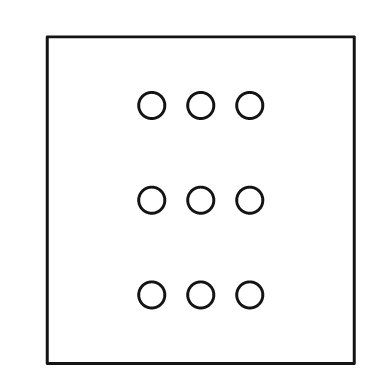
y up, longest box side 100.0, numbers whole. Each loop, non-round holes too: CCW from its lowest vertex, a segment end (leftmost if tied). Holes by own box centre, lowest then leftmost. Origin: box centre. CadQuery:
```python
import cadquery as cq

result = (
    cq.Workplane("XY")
    .moveTo(-47.0, -50.0)
    .lineTo(47.0, -50.0)
    .lineTo(47.0, 50.0)
    .lineTo(-47.0, 50.0)
    .close()
    .moveTo(-15.0, -29.0)
    .circle(4.0)
    .moveTo(0.0, -29.0)
    .circle(4.0)
    .moveTo(15.0, -29.0)
    .circle(4.0)
    .moveTo(-15.0, 0.0)
    .circle(4.0)
    .moveTo(0.0, 0.0)
    .circle(4.0)
    .moveTo(15.0, 0.0)
    .circle(4.0)
    .moveTo(-15.0, 29.0)
    .circle(4.0)
    .moveTo(0.0, 29.0)
    .circle(4.0)
    .moveTo(15.0, 29.0)
    .circle(4.0)
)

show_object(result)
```